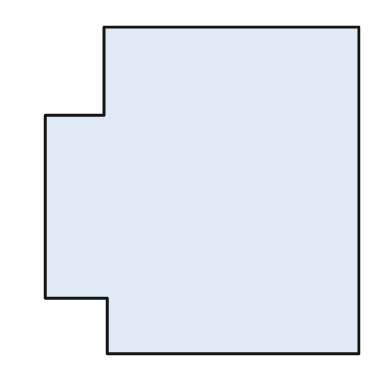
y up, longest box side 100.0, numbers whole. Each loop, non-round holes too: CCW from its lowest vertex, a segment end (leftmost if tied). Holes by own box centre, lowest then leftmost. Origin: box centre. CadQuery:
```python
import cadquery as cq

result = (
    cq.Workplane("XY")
    .moveTo(-29.0, -50.0)
    .lineTo(48.0, -50.0)
    .lineTo(48.0, 50.0)
    .lineTo(-30.0, 50.0)
    .lineTo(-30.0, 23.0)
    .lineTo(-48.0, 23.0)
    .lineTo(-48.0, -33.0)
    .lineTo(-29.0, -33.0)
    .close()
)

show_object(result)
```